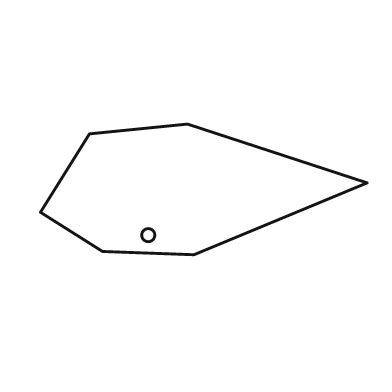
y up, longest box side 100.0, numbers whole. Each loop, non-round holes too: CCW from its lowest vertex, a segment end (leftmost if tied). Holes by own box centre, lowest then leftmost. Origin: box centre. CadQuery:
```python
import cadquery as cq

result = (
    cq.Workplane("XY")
    .moveTo(-3.0, -20.0)
    .lineTo(50.0, 2.0)
    .lineTo(-5.0, 20.0)
    .lineTo(-35.0, 17.0)
    .lineTo(-50.0, -7.0)
    .lineTo(-31.0, -19.0)
    .close()
    .moveTo(-17.0, -14.0)
    .circle(2.0)
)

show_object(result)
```